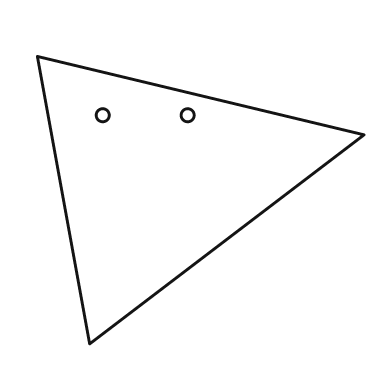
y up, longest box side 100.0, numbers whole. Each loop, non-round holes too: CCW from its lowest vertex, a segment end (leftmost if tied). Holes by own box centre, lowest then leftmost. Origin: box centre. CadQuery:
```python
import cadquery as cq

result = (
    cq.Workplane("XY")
    .moveTo(-34.0, -44.0)
    .lineTo(50.0, 20.0)
    .lineTo(-50.0, 44.0)
    .close()
    .moveTo(-30.0, 26.0)
    .circle(2.0)
    .moveTo(-4.0, 26.0)
    .circle(2.0)
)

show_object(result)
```